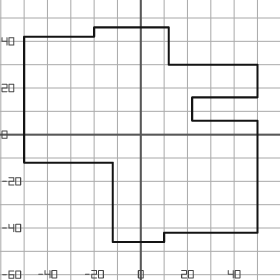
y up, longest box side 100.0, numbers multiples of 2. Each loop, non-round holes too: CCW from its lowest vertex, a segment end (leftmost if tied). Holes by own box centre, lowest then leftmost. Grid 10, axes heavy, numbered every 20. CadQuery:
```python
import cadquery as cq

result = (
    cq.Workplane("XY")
    .moveTo(-12.0, -46.0)
    .lineTo(10.0, -46.0)
    .lineTo(10.0, -42.0)
    .lineTo(50.0, -42.0)
    .lineTo(50.0, 6.0)
    .lineTo(22.0, 6.0)
    .lineTo(22.0, 16.0)
    .lineTo(50.0, 16.0)
    .lineTo(50.0, 30.0)
    .lineTo(12.0, 30.0)
    .lineTo(12.0, 46.0)
    .lineTo(-20.0, 46.0)
    .lineTo(-20.0, 42.0)
    .lineTo(-50.0, 42.0)
    .lineTo(-50.0, -12.0)
    .lineTo(-12.0, -12.0)
    .close()
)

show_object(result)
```